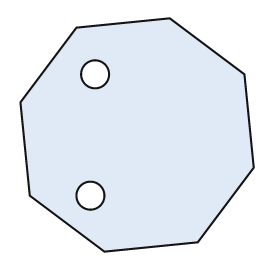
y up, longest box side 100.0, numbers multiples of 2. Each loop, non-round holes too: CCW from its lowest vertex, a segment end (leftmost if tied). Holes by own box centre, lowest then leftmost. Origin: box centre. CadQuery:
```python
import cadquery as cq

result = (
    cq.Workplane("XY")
    .moveTo(-14.0, -50.0)
    .lineTo(26.0, -46.0)
    .lineTo(50.0, -14.0)
    .lineTo(46.0, 26.0)
    .lineTo(14.0, 50.0)
    .lineTo(-26.0, 46.0)
    .lineTo(-50.0, 14.0)
    .lineTo(-46.0, -26.0)
    .close()
    .moveTo(-20.0, -26.0)
    .circle(6.0)
    .moveTo(-18.0, 26.0)
    .circle(6.0)
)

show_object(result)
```